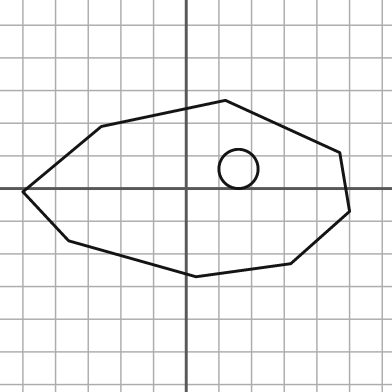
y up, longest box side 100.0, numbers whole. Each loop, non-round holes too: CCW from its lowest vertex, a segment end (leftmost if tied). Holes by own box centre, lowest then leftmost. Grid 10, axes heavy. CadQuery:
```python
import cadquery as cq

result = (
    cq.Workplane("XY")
    .moveTo(3.0, -27.0)
    .lineTo(32.0, -23.0)
    .lineTo(50.0, -7.0)
    .lineTo(47.0, 11.0)
    .lineTo(12.0, 27.0)
    .lineTo(-26.0, 19.0)
    .lineTo(-50.0, -1.0)
    .lineTo(-36.0, -16.0)
    .close()
    .moveTo(16.0, 6.0)
    .circle(6.0)
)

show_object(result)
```